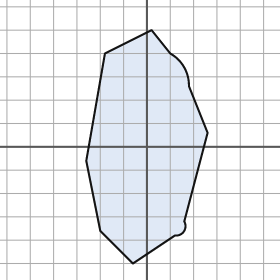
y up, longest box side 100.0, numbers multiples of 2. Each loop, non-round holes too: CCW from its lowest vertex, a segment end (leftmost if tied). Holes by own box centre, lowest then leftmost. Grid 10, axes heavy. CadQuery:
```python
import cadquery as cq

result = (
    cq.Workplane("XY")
    .moveTo(-6.0, -50.0)
    .lineTo(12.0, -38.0)
    .threePointArc((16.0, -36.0), (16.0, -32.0))
    .lineTo(26.0, 6.0)
    .lineTo(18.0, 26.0)
    .threePointArc((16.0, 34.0), (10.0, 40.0))
    .lineTo(2.0, 50.0)
    .lineTo(-18.0, 40.0)
    .lineTo(-26.0, -6.0)
    .lineTo(-20.0, -36.0)
    .close()
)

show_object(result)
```